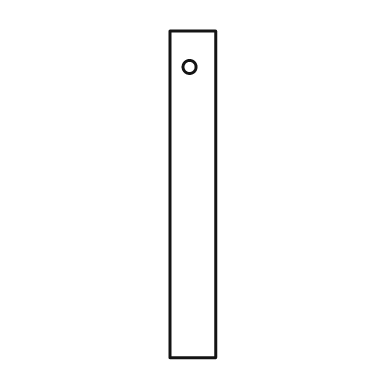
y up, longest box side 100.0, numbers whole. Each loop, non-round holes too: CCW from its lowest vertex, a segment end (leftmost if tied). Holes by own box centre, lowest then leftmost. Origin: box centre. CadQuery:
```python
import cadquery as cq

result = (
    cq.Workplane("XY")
    .moveTo(-7.0, -50.0)
    .lineTo(7.0, -50.0)
    .lineTo(7.0, 50.0)
    .lineTo(-7.0, 50.0)
    .close()
    .moveTo(-1.0, 39.0)
    .circle(2.0)
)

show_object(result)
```